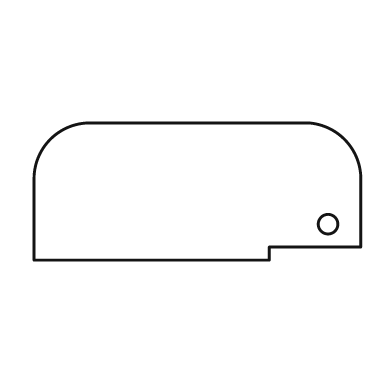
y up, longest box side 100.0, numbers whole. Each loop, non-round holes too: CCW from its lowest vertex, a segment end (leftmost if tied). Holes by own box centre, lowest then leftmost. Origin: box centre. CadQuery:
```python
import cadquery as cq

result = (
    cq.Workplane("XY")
    .moveTo(-50.0, -21.0)
    .lineTo(22.0, -21.0)
    .lineTo(22.0, -17.0)
    .lineTo(50.0, -17.0)
    .lineTo(50.0, 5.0)
    .threePointArc((45.0, 16.0), (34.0, 21.0))
    .lineTo(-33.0, 21.0)
    .threePointArc((-45.0, 16.0), (-50.0, 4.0))
    .close()
    .moveTo(40.0, -10.0)
    .circle(3.0)
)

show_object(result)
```